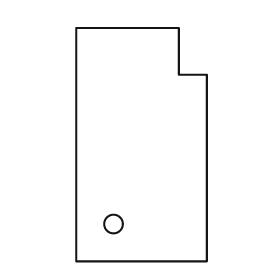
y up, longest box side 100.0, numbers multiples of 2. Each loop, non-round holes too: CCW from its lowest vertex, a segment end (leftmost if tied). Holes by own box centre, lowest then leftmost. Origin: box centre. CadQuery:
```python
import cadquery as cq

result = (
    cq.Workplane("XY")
    .moveTo(-28.0, -50.0)
    .lineTo(28.0, -50.0)
    .lineTo(28.0, 30.0)
    .lineTo(16.0, 30.0)
    .lineTo(16.0, 50.0)
    .lineTo(-28.0, 50.0)
    .close()
    .moveTo(-12.0, -34.0)
    .circle(4.0)
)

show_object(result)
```